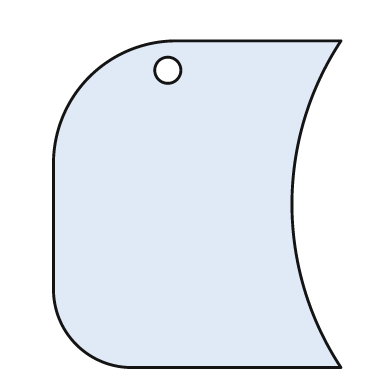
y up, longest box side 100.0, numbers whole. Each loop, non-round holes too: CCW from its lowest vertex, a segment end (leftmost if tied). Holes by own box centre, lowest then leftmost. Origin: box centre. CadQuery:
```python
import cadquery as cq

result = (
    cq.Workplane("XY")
    .moveTo(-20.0, -50.0)
    .lineTo(44.0, -50.0)
    .threePointArc((29.0, 0.0), (44.0, 50.0))
    .lineTo(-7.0, 50.0)
    .threePointArc((-33.0, 39.0), (-44.0, 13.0))
    .lineTo(-44.0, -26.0)
    .threePointArc((-37.0, -43.0), (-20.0, -50.0))
    .close()
    .moveTo(-9.0, 41.0)
    .circle(4.0)
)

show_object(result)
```